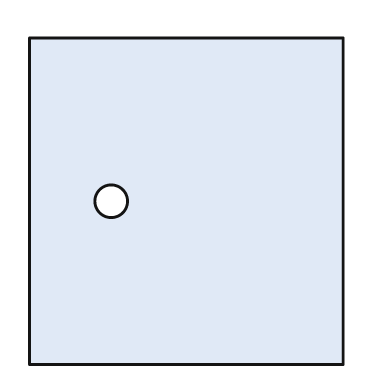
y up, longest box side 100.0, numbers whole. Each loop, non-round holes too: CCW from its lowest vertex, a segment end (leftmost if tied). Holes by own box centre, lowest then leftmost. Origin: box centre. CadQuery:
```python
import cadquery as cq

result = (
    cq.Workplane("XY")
    .moveTo(-48.0, -50.0)
    .lineTo(48.0, -50.0)
    .lineTo(48.0, 50.0)
    .lineTo(-48.0, 50.0)
    .close()
    .moveTo(-23.0, 0.0)
    .circle(5.0)
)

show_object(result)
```